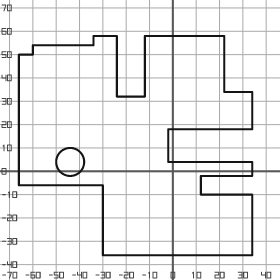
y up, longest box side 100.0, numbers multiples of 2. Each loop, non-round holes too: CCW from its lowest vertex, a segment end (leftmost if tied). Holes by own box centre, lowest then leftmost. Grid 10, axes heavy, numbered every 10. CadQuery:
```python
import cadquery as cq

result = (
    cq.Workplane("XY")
    .moveTo(-30.0, -36.0)
    .lineTo(34.0, -36.0)
    .lineTo(34.0, -10.0)
    .lineTo(12.0, -10.0)
    .lineTo(12.0, -2.0)
    .lineTo(34.0, -2.0)
    .lineTo(34.0, 4.0)
    .lineTo(-2.0, 4.0)
    .lineTo(-2.0, 18.0)
    .lineTo(34.0, 18.0)
    .lineTo(34.0, 34.0)
    .lineTo(22.0, 34.0)
    .lineTo(22.0, 58.0)
    .lineTo(-12.0, 58.0)
    .lineTo(-12.0, 32.0)
    .lineTo(-24.0, 32.0)
    .lineTo(-24.0, 58.0)
    .lineTo(-34.0, 58.0)
    .lineTo(-34.0, 54.0)
    .lineTo(-60.0, 54.0)
    .lineTo(-60.0, 50.0)
    .lineTo(-66.0, 50.0)
    .lineTo(-66.0, -6.0)
    .lineTo(-30.0, -6.0)
    .close()
    .moveTo(-44.0, 4.0)
    .circle(6.0)
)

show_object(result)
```